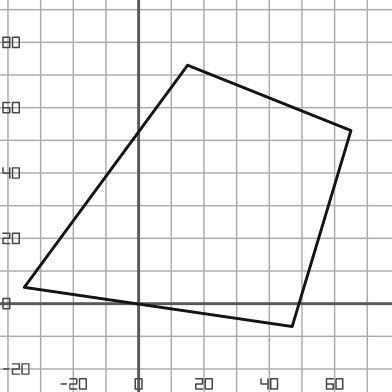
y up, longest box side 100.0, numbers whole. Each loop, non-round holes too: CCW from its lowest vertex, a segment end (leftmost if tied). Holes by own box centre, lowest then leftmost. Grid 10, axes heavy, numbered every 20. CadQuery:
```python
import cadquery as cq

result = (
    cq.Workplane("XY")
    .moveTo(47.0, -7.0)
    .lineTo(65.0, 53.0)
    .lineTo(15.0, 73.0)
    .lineTo(-35.0, 5.0)
    .close()
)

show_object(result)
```